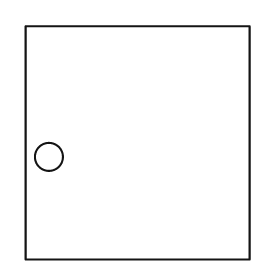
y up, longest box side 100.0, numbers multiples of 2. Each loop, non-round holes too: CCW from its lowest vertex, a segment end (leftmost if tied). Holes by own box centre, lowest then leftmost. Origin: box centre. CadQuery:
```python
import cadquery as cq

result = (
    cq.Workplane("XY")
    .moveTo(-48.0, -50.0)
    .lineTo(48.0, -50.0)
    .lineTo(48.0, 50.0)
    .lineTo(-48.0, 50.0)
    .close()
    .moveTo(-38.0, -6.0)
    .circle(6.0)
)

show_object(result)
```